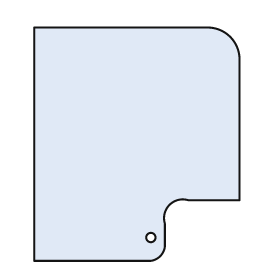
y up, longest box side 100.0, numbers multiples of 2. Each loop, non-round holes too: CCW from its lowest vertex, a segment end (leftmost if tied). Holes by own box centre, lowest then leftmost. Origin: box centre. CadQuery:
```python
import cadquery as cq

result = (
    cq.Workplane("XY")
    .moveTo(-44.0, -50.0)
    .lineTo(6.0, -50.0)
    .threePointArc((10.0, -48.0), (12.0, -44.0))
    .lineTo(12.0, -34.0)
    .threePointArc((14.0, -26.0), (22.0, -24.0))
    .lineTo(44.0, -24.0)
    .lineTo(44.0, 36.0)
    .threePointArc((40.0, 46.0), (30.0, 50.0))
    .lineTo(-44.0, 50.0)
    .close()
    .moveTo(6.0, -40.0)
    .circle(2.0)
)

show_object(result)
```